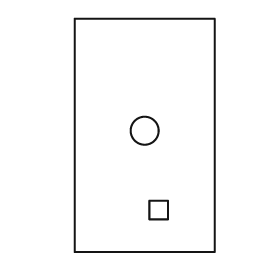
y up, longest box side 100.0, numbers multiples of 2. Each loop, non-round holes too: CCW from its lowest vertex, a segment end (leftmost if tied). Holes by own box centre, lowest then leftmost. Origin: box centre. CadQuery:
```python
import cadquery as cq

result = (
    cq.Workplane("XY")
    .moveTo(-30.0, -50.0)
    .lineTo(30.0, -50.0)
    .lineTo(30.0, 50.0)
    .lineTo(-30.0, 50.0)
    .close()
    .moveTo(2.0, -36.0)
    .lineTo(10.0, -36.0)
    .lineTo(10.0, -28.0)
    .lineTo(2.0, -28.0)
    .close()
    .moveTo(0.0, 2.0)
    .circle(6.0)
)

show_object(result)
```